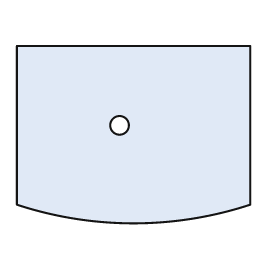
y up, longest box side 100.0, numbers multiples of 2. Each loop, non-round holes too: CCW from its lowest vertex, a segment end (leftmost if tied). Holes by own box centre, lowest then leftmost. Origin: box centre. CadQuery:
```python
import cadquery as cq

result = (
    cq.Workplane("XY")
    .moveTo(-50.0, -30.0)
    .threePointArc((0.0, -38.0), (50.0, -30.0))
    .lineTo(50.0, 38.0)
    .lineTo(-50.0, 38.0)
    .close()
    .moveTo(-6.0, 4.0)
    .circle(4.0)
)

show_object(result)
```